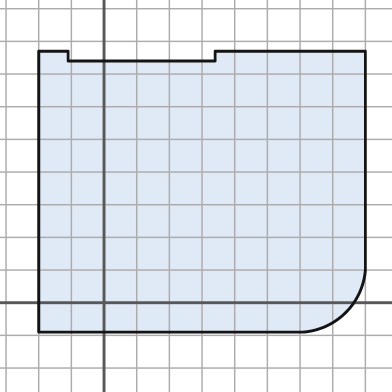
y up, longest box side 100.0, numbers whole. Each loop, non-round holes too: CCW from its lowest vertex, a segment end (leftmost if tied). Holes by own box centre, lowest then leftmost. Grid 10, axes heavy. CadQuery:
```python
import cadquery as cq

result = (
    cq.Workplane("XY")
    .moveTo(-20.0, -9.0)
    .lineTo(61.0, -9.0)
    .threePointArc((74.0, -3.0), (80.0, 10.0))
    .lineTo(80.0, 77.0)
    .lineTo(34.0, 77.0)
    .lineTo(34.0, 74.0)
    .lineTo(-11.0, 74.0)
    .lineTo(-11.0, 77.0)
    .lineTo(-20.0, 77.0)
    .close()
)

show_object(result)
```